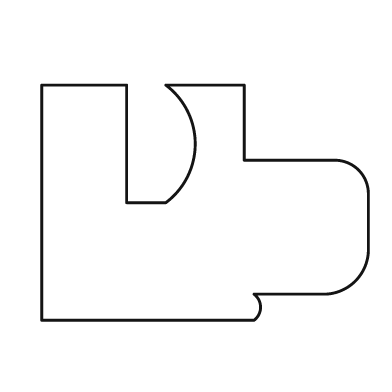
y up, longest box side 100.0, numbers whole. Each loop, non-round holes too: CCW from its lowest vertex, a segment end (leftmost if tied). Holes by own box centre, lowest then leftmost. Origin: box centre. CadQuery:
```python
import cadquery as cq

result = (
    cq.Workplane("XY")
    .moveTo(-50.0, -36.0)
    .lineTo(15.0, -36.0)
    .threePointArc((17.0, -32.0), (15.0, -28.0))
    .lineTo(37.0, -28.0)
    .threePointArc((46.0, -24.0), (50.0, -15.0))
    .lineTo(50.0, 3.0)
    .threePointArc((47.0, 10.0), (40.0, 13.0))
    .lineTo(12.0, 13.0)
    .lineTo(12.0, 36.0)
    .lineTo(-12.0, 36.0)
    .threePointArc((-3.0, 18.0), (-12.0, 0.0))
    .lineTo(-24.0, 0.0)
    .lineTo(-24.0, 36.0)
    .lineTo(-50.0, 36.0)
    .close()
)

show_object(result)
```